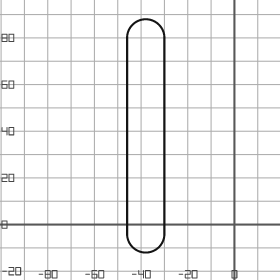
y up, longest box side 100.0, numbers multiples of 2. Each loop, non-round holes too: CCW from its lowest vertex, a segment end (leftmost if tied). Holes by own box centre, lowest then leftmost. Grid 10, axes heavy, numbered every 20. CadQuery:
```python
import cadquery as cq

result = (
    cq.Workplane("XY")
    .moveTo(-46.0, -4.0)
    .threePointArc((-38.0, -12.0), (-30.0, -4.0))
    .lineTo(-30.0, 80.0)
    .threePointArc((-38.0, 88.0), (-46.0, 80.0))
    .close()
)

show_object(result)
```